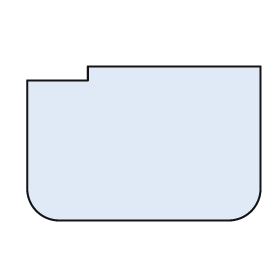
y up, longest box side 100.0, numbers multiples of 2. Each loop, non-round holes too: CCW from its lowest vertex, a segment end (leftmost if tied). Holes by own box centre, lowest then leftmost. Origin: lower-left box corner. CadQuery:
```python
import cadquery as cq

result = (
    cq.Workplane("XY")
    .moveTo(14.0, 0.0)
    .lineTo(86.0, 0.0)
    .threePointArc((96.0, 4.0), (100.0, 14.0))
    .lineTo(100.0, 66.0)
    .lineTo(26.0, 66.0)
    .lineTo(26.0, 60.0)
    .lineTo(0.0, 60.0)
    .lineTo(0.0, 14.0)
    .threePointArc((4.0, 4.0), (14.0, 0.0))
    .close()
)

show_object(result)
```